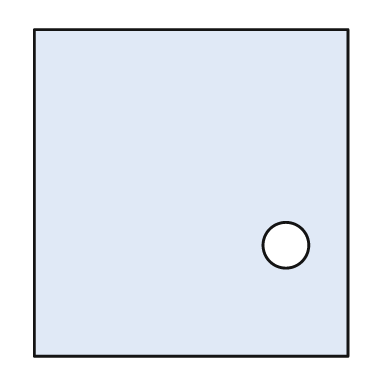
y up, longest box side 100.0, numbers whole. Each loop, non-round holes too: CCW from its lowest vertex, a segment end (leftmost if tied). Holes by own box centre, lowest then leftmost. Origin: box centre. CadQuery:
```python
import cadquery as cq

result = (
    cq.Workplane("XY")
    .moveTo(-48.0, -50.0)
    .lineTo(48.0, -50.0)
    .lineTo(48.0, 50.0)
    .lineTo(-48.0, 50.0)
    .close()
    .moveTo(29.0, -16.0)
    .circle(7.0)
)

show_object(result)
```